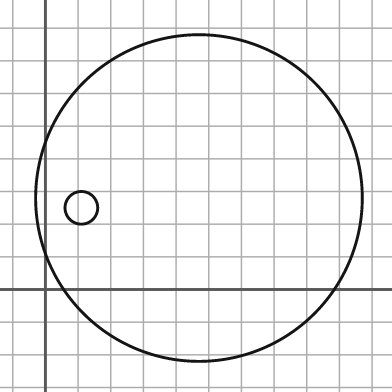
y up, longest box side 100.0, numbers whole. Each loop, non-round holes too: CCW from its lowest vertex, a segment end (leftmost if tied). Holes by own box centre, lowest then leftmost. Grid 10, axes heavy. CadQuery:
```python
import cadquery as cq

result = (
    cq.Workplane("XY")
    .moveTo(47.0, 28.0)
    .circle(50.0)
    .moveTo(11.0, 25.0)
    .circle(5.0)
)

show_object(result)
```